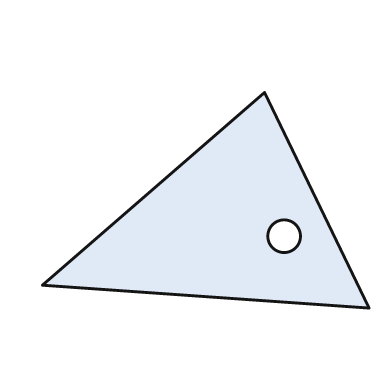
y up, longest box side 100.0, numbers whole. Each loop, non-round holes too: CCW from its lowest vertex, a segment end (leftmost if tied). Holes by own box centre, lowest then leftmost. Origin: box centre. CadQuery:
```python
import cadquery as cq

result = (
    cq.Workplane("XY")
    .moveTo(50.0, -33.0)
    .lineTo(18.0, 33.0)
    .lineTo(-50.0, -26.0)
    .close()
    .moveTo(24.0, -11.0)
    .circle(5.0)
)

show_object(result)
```